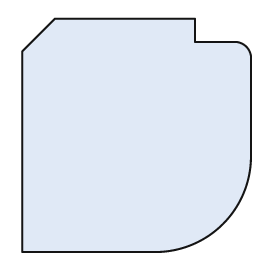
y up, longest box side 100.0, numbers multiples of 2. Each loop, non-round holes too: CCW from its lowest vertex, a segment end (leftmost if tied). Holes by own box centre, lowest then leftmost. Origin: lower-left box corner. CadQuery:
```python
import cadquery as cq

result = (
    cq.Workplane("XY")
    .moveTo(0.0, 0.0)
    .lineTo(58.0, 0.0)
    .threePointArc((86.0, 12.0), (98.0, 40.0))
    .lineTo(98.0, 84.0)
    .threePointArc((96.0, 88.0), (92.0, 90.0))
    .lineTo(74.0, 90.0)
    .lineTo(74.0, 100.0)
    .lineTo(14.0, 100.0)
    .lineTo(0.0, 86.0)
    .close()
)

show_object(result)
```